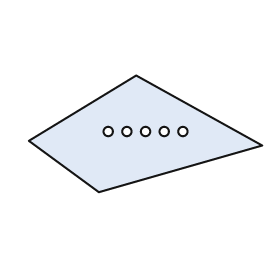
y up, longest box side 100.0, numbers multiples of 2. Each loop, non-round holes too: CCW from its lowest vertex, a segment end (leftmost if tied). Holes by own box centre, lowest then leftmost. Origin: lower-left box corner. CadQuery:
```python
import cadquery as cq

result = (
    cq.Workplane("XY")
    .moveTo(30.0, 0.0)
    .lineTo(100.0, 20.0)
    .lineTo(46.0, 50.0)
    .lineTo(0.0, 22.0)
    .close()
    .moveTo(34.0, 26.0)
    .circle(2.0)
    .moveTo(42.0, 26.0)
    .circle(2.0)
    .moveTo(50.0, 26.0)
    .circle(2.0)
    .moveTo(58.0, 26.0)
    .circle(2.0)
    .moveTo(66.0, 26.0)
    .circle(2.0)
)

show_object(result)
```